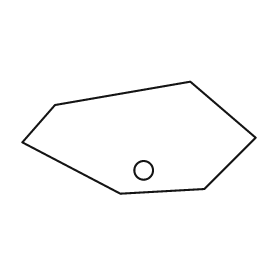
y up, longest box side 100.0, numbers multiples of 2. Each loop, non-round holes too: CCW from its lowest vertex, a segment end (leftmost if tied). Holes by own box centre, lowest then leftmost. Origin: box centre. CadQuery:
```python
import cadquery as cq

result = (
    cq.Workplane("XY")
    .moveTo(-8.0, -24.0)
    .lineTo(28.0, -22.0)
    .lineTo(50.0, 0.0)
    .lineTo(22.0, 24.0)
    .lineTo(-36.0, 14.0)
    .lineTo(-50.0, -2.0)
    .close()
    .moveTo(2.0, -14.0)
    .circle(4.0)
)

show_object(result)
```